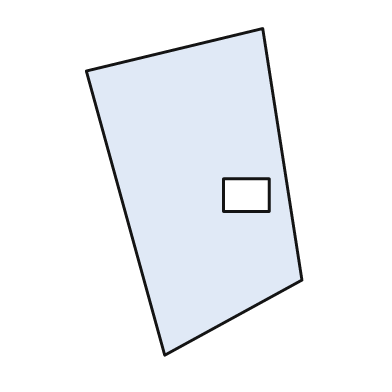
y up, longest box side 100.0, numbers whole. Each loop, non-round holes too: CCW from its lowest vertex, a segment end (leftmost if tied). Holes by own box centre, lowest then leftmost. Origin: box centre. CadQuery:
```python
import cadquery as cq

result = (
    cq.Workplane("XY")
    .moveTo(-9.0, -50.0)
    .lineTo(33.0, -27.0)
    .lineTo(21.0, 50.0)
    .lineTo(-33.0, 37.0)
    .close()
    .moveTo(9.0, -6.0)
    .lineTo(23.0, -6.0)
    .lineTo(23.0, 4.0)
    .lineTo(9.0, 4.0)
    .close()
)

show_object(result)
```